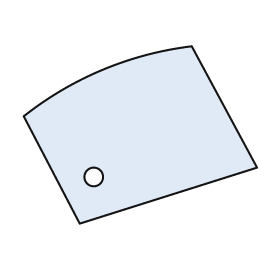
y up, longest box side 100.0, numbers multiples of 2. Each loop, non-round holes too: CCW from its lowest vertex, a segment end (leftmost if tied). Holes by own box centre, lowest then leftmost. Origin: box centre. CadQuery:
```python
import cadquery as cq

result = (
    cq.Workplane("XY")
    .moveTo(-26.0, -38.0)
    .lineTo(50.0, -14.0)
    .lineTo(22.0, 38.0)
    .threePointArc((-16.0, 28.0), (-50.0, 8.0))
    .close()
    .moveTo(-20.0, -18.0)
    .circle(4.0)
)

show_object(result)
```